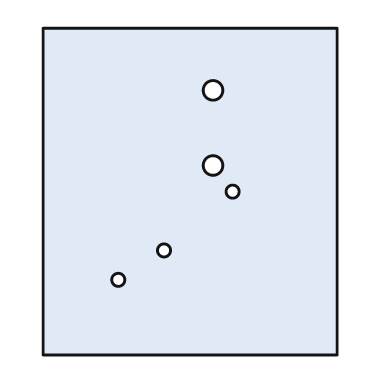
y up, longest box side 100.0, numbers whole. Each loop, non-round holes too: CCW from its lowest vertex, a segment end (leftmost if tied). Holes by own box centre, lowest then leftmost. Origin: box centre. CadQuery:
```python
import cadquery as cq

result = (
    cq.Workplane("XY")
    .moveTo(-45.0, -50.0)
    .lineTo(45.0, -50.0)
    .lineTo(45.0, 50.0)
    .lineTo(-45.0, 50.0)
    .close()
    .moveTo(-22.0, -27.0)
    .circle(2.0)
    .moveTo(-8.0, -18.0)
    .circle(2.0)
    .moveTo(13.0, 0.0)
    .circle(2.0)
    .moveTo(7.0, 8.0)
    .circle(3.0)
    .moveTo(7.0, 31.0)
    .circle(3.0)
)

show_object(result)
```